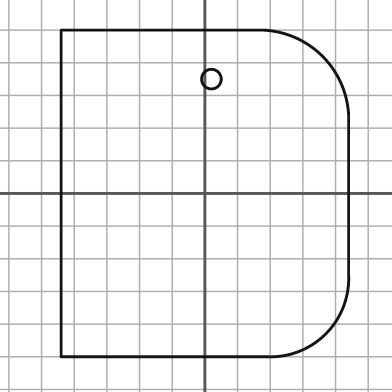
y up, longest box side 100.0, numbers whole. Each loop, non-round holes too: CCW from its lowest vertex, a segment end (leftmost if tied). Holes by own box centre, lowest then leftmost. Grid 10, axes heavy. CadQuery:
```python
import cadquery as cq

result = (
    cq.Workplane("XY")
    .moveTo(-44.0, -50.0)
    .lineTo(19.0, -50.0)
    .threePointArc((37.0, -43.0), (44.0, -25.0))
    .lineTo(44.0, 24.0)
    .threePointArc((36.0, 42.0), (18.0, 50.0))
    .lineTo(-44.0, 50.0)
    .close()
    .moveTo(2.0, 35.0)
    .circle(3.0)
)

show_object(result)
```